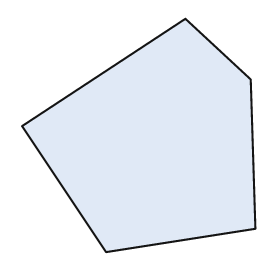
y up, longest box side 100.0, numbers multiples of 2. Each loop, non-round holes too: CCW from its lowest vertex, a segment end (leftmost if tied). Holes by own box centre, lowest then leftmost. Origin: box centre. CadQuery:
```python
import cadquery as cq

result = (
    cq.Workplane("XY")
    .moveTo(-14.0, -50.0)
    .lineTo(50.0, -40.0)
    .lineTo(48.0, 24.0)
    .lineTo(20.0, 50.0)
    .lineTo(-50.0, 4.0)
    .close()
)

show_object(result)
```